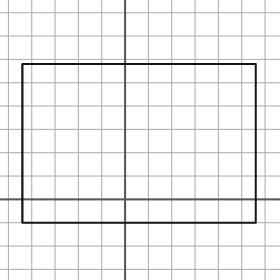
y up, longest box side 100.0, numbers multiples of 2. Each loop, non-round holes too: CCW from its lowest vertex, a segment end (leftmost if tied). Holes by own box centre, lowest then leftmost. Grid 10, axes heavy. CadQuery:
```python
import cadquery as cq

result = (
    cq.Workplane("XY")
    .moveTo(-44.0, -10.0)
    .lineTo(56.0, -10.0)
    .lineTo(56.0, 58.0)
    .lineTo(-44.0, 58.0)
    .close()
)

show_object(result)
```